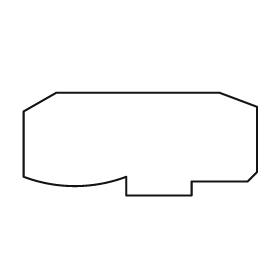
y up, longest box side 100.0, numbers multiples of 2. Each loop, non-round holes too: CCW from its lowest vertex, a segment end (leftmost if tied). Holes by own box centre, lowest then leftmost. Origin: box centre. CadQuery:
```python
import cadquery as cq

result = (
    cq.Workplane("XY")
    .moveTo(-6.0, -22.0)
    .lineTo(22.0, -22.0)
    .lineTo(22.0, -16.0)
    .lineTo(46.0, -16.0)
    .lineTo(50.0, -12.0)
    .lineTo(50.0, 16.0)
    .lineTo(34.0, 22.0)
    .lineTo(-36.0, 22.0)
    .lineTo(-50.0, 14.0)
    .lineTo(-50.0, -14.0)
    .threePointArc((-28.0, -18.0), (-6.0, -14.0))
    .close()
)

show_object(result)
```